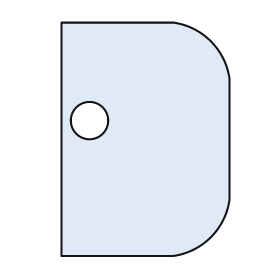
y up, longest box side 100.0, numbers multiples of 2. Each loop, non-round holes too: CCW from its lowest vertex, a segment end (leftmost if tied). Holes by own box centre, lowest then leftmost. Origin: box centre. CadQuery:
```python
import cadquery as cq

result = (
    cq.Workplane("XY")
    .moveTo(-36.0, -50.0)
    .lineTo(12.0, -50.0)
    .threePointArc((28.0, -42.0), (36.0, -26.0))
    .lineTo(36.0, 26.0)
    .threePointArc((28.0, 42.0), (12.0, 50.0))
    .lineTo(-36.0, 50.0)
    .close()
    .moveTo(-24.0, 8.0)
    .circle(8.0)
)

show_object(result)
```